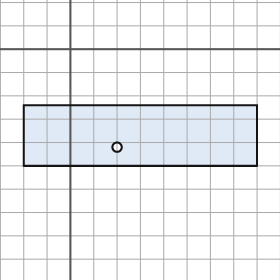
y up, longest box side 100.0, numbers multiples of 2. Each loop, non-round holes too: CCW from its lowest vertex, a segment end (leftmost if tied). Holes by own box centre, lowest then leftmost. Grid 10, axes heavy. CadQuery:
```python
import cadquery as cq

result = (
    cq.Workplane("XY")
    .moveTo(-20.0, -50.0)
    .lineTo(80.0, -50.0)
    .lineTo(80.0, -24.0)
    .lineTo(-20.0, -24.0)
    .close()
    .moveTo(20.0, -42.0)
    .circle(2.0)
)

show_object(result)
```